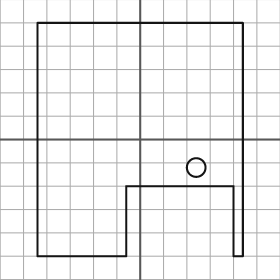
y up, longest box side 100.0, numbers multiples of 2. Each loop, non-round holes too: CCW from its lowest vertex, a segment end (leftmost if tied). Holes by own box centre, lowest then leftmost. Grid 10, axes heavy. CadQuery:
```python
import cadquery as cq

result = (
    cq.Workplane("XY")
    .moveTo(-44.0, -50.0)
    .lineTo(-6.0, -50.0)
    .lineTo(-6.0, -20.0)
    .lineTo(40.0, -20.0)
    .lineTo(40.0, -50.0)
    .lineTo(44.0, -50.0)
    .lineTo(44.0, 50.0)
    .lineTo(-44.0, 50.0)
    .close()
    .moveTo(24.0, -12.0)
    .circle(4.0)
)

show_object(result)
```